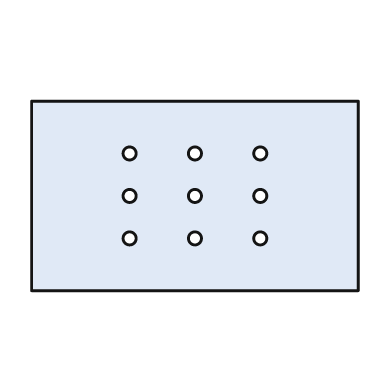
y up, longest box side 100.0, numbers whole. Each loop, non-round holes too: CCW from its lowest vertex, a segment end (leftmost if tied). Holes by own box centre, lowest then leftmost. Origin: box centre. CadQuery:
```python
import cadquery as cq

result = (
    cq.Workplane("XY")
    .moveTo(-50.0, -29.0)
    .lineTo(50.0, -29.0)
    .lineTo(50.0, 29.0)
    .lineTo(-50.0, 29.0)
    .close()
    .moveTo(-20.0, -13.0)
    .circle(2.0)
    .moveTo(0.0, -13.0)
    .circle(2.0)
    .moveTo(20.0, -13.0)
    .circle(2.0)
    .moveTo(-20.0, 0.0)
    .circle(2.0)
    .moveTo(0.0, 0.0)
    .circle(2.0)
    .moveTo(20.0, 0.0)
    .circle(2.0)
    .moveTo(-20.0, 13.0)
    .circle(2.0)
    .moveTo(0.0, 13.0)
    .circle(2.0)
    .moveTo(20.0, 13.0)
    .circle(2.0)
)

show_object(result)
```